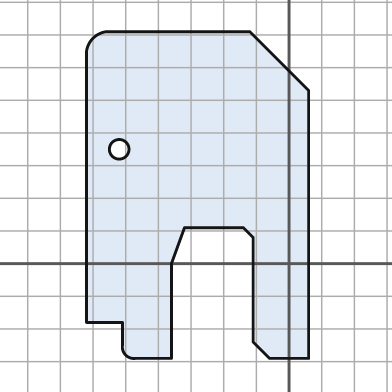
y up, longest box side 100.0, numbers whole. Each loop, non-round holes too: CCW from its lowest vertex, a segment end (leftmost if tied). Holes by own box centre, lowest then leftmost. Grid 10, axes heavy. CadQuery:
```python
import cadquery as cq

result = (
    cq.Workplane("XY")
    .moveTo(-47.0, -29.0)
    .lineTo(-36.0, -29.0)
    .lineTo(-36.0, 0.0)
    .lineTo(-32.0, 11.0)
    .lineTo(-14.0, 11.0)
    .lineTo(-11.0, 8.0)
    .lineTo(-11.0, -24.0)
    .lineTo(-6.0, -29.0)
    .lineTo(6.0, -29.0)
    .lineTo(6.0, 53.0)
    .lineTo(-12.0, 71.0)
    .lineTo(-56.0, 71.0)
    .threePointArc((-60.0, 69.0), (-62.0, 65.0))
    .lineTo(-62.0, -18.0)
    .lineTo(-51.0, -18.0)
    .lineTo(-51.0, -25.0)
    .threePointArc((-50.0, -28.0), (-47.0, -29.0))
    .close()
    .moveTo(-52.0, 35.0)
    .circle(3.0)
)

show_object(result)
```